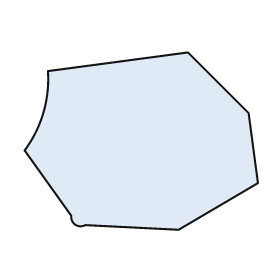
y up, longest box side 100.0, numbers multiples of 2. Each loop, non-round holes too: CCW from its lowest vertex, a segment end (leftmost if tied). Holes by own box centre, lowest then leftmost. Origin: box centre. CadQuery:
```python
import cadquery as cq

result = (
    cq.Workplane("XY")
    .moveTo(16.0, -38.0)
    .lineTo(50.0, -18.0)
    .lineTo(46.0, 12.0)
    .lineTo(20.0, 38.0)
    .lineTo(-40.0, 30.0)
    .threePointArc((-42.0, 12.0), (-50.0, -4.0))
    .lineTo(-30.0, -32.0)
    .threePointArc((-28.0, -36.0), (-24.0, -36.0))
    .close()
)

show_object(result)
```